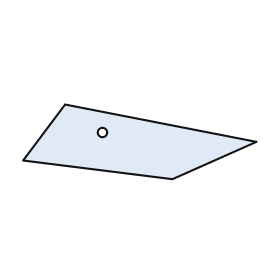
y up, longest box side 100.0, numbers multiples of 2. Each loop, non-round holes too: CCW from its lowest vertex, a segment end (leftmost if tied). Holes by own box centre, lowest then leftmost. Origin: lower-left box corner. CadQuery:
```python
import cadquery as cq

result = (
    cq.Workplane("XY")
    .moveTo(64.0, 0.0)
    .lineTo(100.0, 16.0)
    .lineTo(18.0, 32.0)
    .lineTo(0.0, 8.0)
    .close()
    .moveTo(34.0, 20.0)
    .circle(2.0)
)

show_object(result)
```